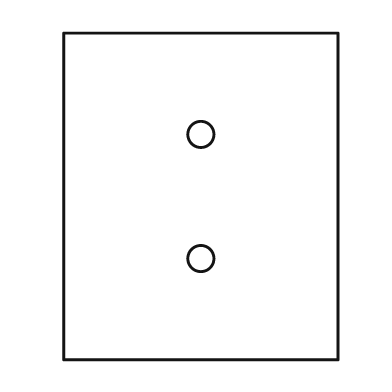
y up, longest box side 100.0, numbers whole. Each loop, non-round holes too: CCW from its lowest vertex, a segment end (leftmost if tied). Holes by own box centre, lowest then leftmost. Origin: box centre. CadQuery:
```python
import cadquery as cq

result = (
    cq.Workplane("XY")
    .moveTo(-42.0, -50.0)
    .lineTo(42.0, -50.0)
    .lineTo(42.0, 50.0)
    .lineTo(-42.0, 50.0)
    .close()
    .moveTo(0.0, -19.0)
    .circle(4.0)
    .moveTo(0.0, 19.0)
    .circle(4.0)
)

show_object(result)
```